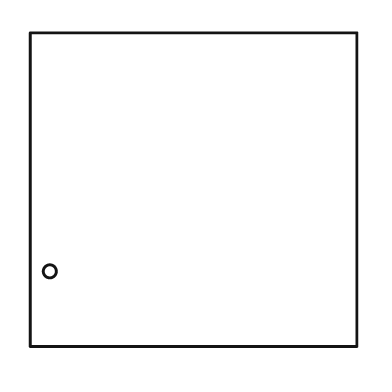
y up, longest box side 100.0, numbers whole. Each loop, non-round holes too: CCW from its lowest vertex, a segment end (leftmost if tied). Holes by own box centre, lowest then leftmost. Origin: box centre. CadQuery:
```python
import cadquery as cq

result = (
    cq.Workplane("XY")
    .moveTo(-50.0, -48.0)
    .lineTo(50.0, -48.0)
    .lineTo(50.0, 48.0)
    .lineTo(-50.0, 48.0)
    .close()
    .moveTo(-44.0, -25.0)
    .circle(2.0)
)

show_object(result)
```